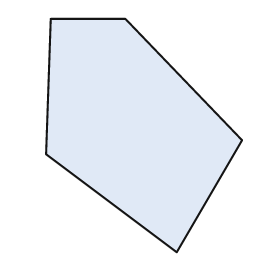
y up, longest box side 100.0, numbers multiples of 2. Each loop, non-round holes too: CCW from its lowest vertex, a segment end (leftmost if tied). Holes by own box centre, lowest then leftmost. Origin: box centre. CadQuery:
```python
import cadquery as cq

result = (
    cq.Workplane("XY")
    .moveTo(14.0, -50.0)
    .lineTo(42.0, -2.0)
    .lineTo(-8.0, 50.0)
    .lineTo(-40.0, 50.0)
    .lineTo(-42.0, -8.0)
    .close()
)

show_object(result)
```